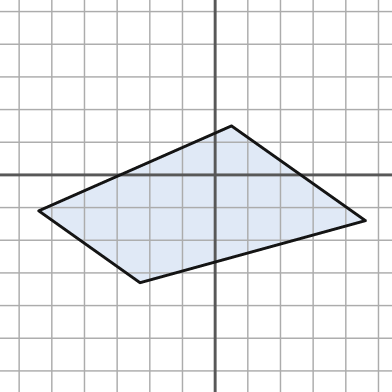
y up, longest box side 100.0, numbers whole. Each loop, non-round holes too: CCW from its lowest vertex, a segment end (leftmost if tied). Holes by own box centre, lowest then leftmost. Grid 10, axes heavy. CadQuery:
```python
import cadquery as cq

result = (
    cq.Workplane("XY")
    .moveTo(-23.0, -33.0)
    .lineTo(46.0, -14.0)
    .lineTo(5.0, 15.0)
    .lineTo(-54.0, -11.0)
    .close()
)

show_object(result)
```